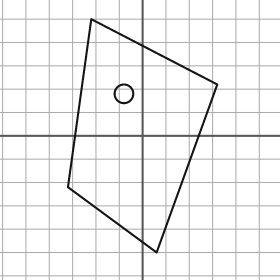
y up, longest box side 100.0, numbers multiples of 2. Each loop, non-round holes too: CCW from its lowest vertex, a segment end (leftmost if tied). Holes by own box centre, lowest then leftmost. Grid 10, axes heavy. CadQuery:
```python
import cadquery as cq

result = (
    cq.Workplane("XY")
    .moveTo(6.0, -50.0)
    .lineTo(32.0, 22.0)
    .lineTo(-22.0, 50.0)
    .lineTo(-32.0, -22.0)
    .close()
    .moveTo(-8.0, 18.0)
    .circle(4.0)
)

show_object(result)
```